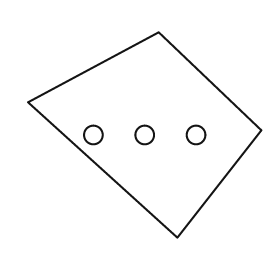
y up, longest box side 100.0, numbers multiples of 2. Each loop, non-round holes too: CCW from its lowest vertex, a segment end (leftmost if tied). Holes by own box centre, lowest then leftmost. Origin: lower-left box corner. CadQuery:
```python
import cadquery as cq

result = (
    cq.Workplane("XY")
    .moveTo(64.0, 0.0)
    .lineTo(100.0, 46.0)
    .lineTo(56.0, 88.0)
    .lineTo(0.0, 58.0)
    .close()
    .moveTo(28.0, 44.0)
    .circle(4.0)
    .moveTo(50.0, 44.0)
    .circle(4.0)
    .moveTo(72.0, 44.0)
    .circle(4.0)
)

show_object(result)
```